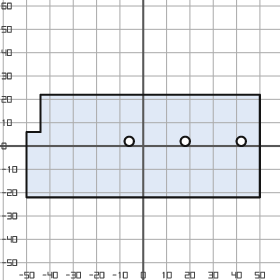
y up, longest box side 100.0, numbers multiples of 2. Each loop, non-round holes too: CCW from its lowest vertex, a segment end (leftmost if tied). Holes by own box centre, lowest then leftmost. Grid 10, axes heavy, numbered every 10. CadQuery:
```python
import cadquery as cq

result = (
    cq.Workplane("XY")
    .moveTo(-50.0, -22.0)
    .lineTo(50.0, -22.0)
    .lineTo(50.0, 22.0)
    .lineTo(-44.0, 22.0)
    .lineTo(-44.0, 6.0)
    .lineTo(-50.0, 6.0)
    .close()
    .moveTo(-6.0, 2.0)
    .circle(2.0)
    .moveTo(18.0, 2.0)
    .circle(2.0)
    .moveTo(42.0, 2.0)
    .circle(2.0)
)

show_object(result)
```